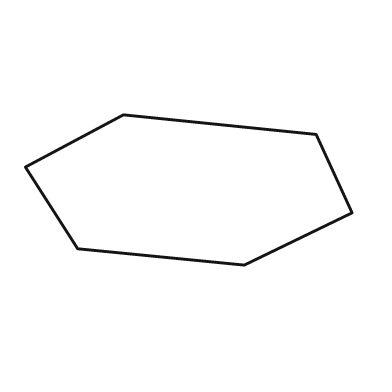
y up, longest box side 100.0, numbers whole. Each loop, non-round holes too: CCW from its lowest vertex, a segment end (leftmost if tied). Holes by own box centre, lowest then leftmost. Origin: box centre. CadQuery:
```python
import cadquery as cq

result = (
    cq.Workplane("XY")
    .moveTo(17.0, -23.0)
    .lineTo(50.0, -7.0)
    .lineTo(39.0, 17.0)
    .lineTo(-20.0, 23.0)
    .lineTo(-50.0, 7.0)
    .lineTo(-34.0, -18.0)
    .close()
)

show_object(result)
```